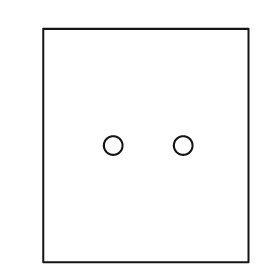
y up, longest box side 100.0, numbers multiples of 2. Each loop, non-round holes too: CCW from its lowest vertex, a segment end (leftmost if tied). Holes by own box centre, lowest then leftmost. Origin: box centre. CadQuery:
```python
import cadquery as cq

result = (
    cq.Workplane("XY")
    .moveTo(-44.0, -50.0)
    .lineTo(44.0, -50.0)
    .lineTo(44.0, 50.0)
    .lineTo(-44.0, 50.0)
    .close()
    .moveTo(-14.0, 0.0)
    .circle(4.0)
    .moveTo(16.0, 0.0)
    .circle(4.0)
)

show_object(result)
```